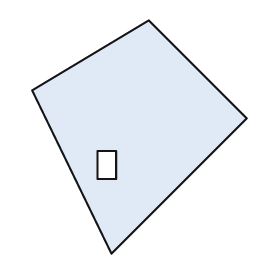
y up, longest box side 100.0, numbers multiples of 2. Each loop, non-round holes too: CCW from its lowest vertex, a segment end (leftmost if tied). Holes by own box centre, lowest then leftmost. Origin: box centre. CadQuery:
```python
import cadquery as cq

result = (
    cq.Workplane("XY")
    .moveTo(-12.0, -50.0)
    .lineTo(46.0, 8.0)
    .lineTo(4.0, 50.0)
    .lineTo(-46.0, 20.0)
    .close()
    .moveTo(-18.0, -18.0)
    .lineTo(-10.0, -18.0)
    .lineTo(-10.0, -6.0)
    .lineTo(-18.0, -6.0)
    .close()
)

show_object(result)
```